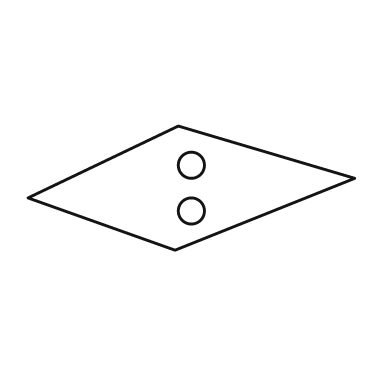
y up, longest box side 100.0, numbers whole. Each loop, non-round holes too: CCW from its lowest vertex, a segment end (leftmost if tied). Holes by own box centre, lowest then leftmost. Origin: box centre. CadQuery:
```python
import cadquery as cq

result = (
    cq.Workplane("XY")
    .moveTo(-5.0, -19.0)
    .lineTo(50.0, 3.0)
    .lineTo(-4.0, 19.0)
    .lineTo(-50.0, -3.0)
    .close()
    .moveTo(0.0, -7.0)
    .circle(4.0)
    .moveTo(0.0, 7.0)
    .circle(4.0)
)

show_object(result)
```